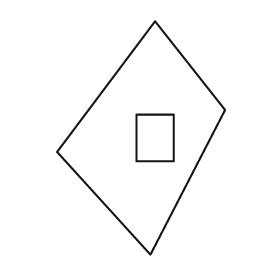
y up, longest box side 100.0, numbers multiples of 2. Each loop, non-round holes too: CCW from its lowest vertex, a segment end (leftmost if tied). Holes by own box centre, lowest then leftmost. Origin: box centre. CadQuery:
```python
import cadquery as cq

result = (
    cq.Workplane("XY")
    .moveTo(4.0, -50.0)
    .lineTo(36.0, 12.0)
    .lineTo(6.0, 50.0)
    .lineTo(-36.0, -6.0)
    .close()
    .moveTo(-2.0, -10.0)
    .lineTo(14.0, -10.0)
    .lineTo(14.0, 10.0)
    .lineTo(-2.0, 10.0)
    .close()
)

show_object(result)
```